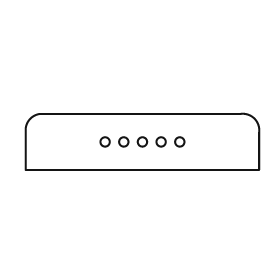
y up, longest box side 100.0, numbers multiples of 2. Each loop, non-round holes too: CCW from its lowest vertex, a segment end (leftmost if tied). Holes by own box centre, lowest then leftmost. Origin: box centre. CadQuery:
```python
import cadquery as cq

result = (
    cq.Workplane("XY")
    .moveTo(-50.0, -12.0)
    .lineTo(50.0, -12.0)
    .lineTo(50.0, 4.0)
    .threePointArc((48.0, 10.0), (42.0, 12.0))
    .lineTo(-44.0, 12.0)
    .threePointArc((-48.0, 10.0), (-50.0, 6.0))
    .close()
    .moveTo(-16.0, 0.0)
    .circle(2.0)
    .moveTo(-8.0, 0.0)
    .circle(2.0)
    .moveTo(0.0, 0.0)
    .circle(2.0)
    .moveTo(8.0, 0.0)
    .circle(2.0)
    .moveTo(16.0, 0.0)
    .circle(2.0)
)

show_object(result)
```